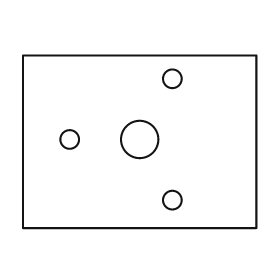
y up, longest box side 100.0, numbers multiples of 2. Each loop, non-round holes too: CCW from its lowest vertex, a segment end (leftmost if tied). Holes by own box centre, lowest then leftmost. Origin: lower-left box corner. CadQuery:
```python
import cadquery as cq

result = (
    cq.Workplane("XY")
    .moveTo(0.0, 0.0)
    .lineTo(100.0, 0.0)
    .lineTo(100.0, 74.0)
    .lineTo(0.0, 74.0)
    .close()
    .moveTo(64.0, 12.0)
    .circle(4.0)
    .moveTo(20.0, 38.0)
    .circle(4.0)
    .moveTo(50.0, 38.0)
    .circle(8.0)
    .moveTo(64.0, 64.0)
    .circle(4.0)
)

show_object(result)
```